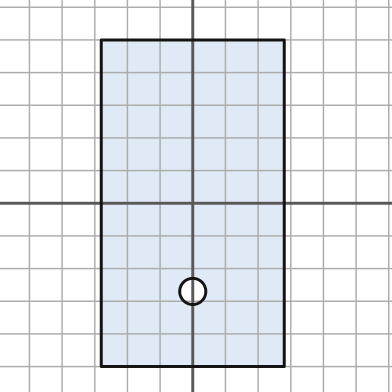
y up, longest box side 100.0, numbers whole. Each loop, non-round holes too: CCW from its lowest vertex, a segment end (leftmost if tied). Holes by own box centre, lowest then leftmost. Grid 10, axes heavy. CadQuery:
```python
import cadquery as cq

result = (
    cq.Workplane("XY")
    .moveTo(-28.0, -50.0)
    .lineTo(28.0, -50.0)
    .lineTo(28.0, 50.0)
    .lineTo(-28.0, 50.0)
    .close()
    .moveTo(0.0, -27.0)
    .circle(4.0)
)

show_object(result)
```